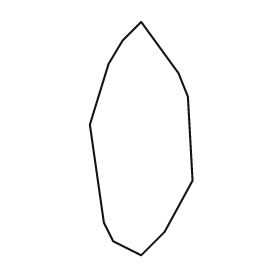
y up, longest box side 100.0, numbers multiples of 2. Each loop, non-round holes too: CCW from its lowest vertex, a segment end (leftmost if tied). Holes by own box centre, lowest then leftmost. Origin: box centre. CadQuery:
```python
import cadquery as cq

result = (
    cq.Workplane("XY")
    .moveTo(0.0, -50.0)
    .lineTo(10.0, -40.0)
    .lineTo(22.0, -18.0)
    .lineTo(20.0, 18.0)
    .lineTo(16.0, 28.0)
    .lineTo(0.0, 50.0)
    .lineTo(-8.0, 42.0)
    .lineTo(-14.0, 32.0)
    .lineTo(-22.0, 6.0)
    .lineTo(-16.0, -36.0)
    .lineTo(-12.0, -44.0)
    .close()
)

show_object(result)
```